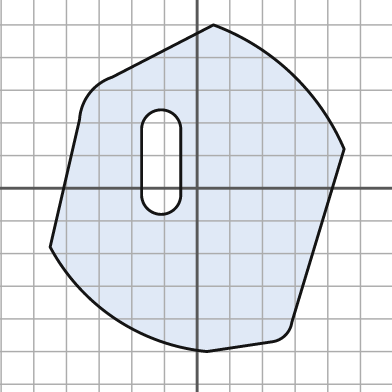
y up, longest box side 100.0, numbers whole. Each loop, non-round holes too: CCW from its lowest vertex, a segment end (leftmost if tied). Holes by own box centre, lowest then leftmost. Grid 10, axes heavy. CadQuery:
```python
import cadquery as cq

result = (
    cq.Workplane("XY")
    .moveTo(3.0, -50.0)
    .lineTo(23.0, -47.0)
    .threePointArc((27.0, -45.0), (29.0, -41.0))
    .lineTo(45.0, 12.0)
    .threePointArc((29.0, 35.0), (5.0, 50.0))
    .lineTo(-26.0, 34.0)
    .threePointArc((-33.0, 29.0), (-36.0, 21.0))
    .lineTo(-45.0, -18.0)
    .threePointArc((-25.0, -40.0), (3.0, -50.0))
    .close()
    .moveTo(-17.0, -2.0)
    .threePointArc((-11.0, -8.0), (-5.0, -2.0))
    .lineTo(-5.0, 18.0)
    .threePointArc((-11.0, 24.0), (-17.0, 18.0))
    .close()
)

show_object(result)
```